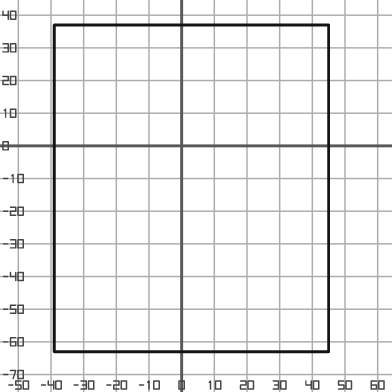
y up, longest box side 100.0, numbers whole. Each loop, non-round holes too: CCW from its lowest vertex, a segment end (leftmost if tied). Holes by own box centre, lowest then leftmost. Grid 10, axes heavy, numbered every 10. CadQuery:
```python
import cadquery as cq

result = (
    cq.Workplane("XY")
    .moveTo(-39.0, -63.0)
    .lineTo(45.0, -63.0)
    .lineTo(45.0, 37.0)
    .lineTo(-39.0, 37.0)
    .close()
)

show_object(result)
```